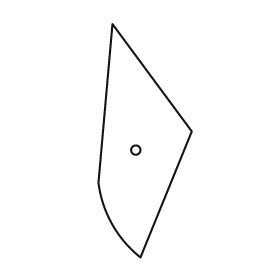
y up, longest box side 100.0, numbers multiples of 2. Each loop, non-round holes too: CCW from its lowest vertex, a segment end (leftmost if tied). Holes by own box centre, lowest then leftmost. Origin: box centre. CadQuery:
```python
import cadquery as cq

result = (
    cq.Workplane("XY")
    .moveTo(-2.0, -50.0)
    .lineTo(20.0, 4.0)
    .lineTo(-14.0, 50.0)
    .lineTo(-20.0, -18.0)
    .threePointArc((-14.0, -36.0), (-2.0, -50.0))
    .close()
    .moveTo(-4.0, -4.0)
    .circle(2.0)
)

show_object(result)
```